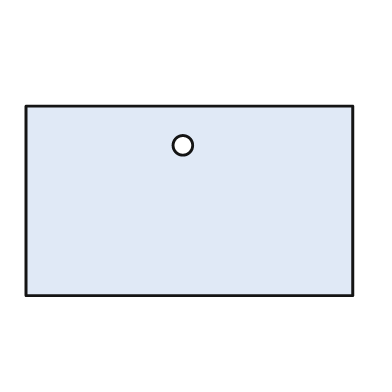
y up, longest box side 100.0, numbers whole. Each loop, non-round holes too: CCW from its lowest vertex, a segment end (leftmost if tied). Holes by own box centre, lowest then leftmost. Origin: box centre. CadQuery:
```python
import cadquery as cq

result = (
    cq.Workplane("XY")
    .moveTo(-50.0, -29.0)
    .lineTo(50.0, -29.0)
    .lineTo(50.0, 29.0)
    .lineTo(-50.0, 29.0)
    .close()
    .moveTo(-2.0, 17.0)
    .circle(3.0)
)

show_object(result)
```